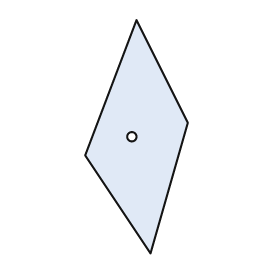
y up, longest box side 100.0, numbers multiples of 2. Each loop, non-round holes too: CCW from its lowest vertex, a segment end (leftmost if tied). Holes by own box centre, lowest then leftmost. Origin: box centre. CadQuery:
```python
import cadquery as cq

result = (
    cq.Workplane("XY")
    .moveTo(6.0, -50.0)
    .lineTo(22.0, 6.0)
    .lineTo(0.0, 50.0)
    .lineTo(-22.0, -8.0)
    .close()
    .moveTo(-2.0, 0.0)
    .circle(2.0)
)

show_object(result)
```